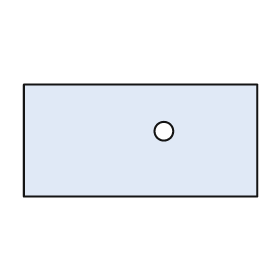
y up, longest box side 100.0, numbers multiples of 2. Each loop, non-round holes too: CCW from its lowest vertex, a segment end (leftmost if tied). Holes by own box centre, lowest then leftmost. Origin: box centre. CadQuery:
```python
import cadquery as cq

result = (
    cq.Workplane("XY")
    .moveTo(-50.0, -24.0)
    .lineTo(50.0, -24.0)
    .lineTo(50.0, 24.0)
    .lineTo(-50.0, 24.0)
    .close()
    .moveTo(10.0, 4.0)
    .circle(4.0)
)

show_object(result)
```